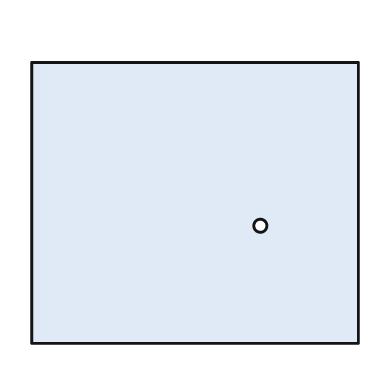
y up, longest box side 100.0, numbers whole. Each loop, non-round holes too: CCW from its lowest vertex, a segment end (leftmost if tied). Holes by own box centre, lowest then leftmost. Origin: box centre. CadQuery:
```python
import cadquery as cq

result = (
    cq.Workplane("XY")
    .moveTo(-50.0, -43.0)
    .lineTo(50.0, -43.0)
    .lineTo(50.0, 43.0)
    .lineTo(-50.0, 43.0)
    .close()
    .moveTo(20.0, -7.0)
    .circle(2.0)
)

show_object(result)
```